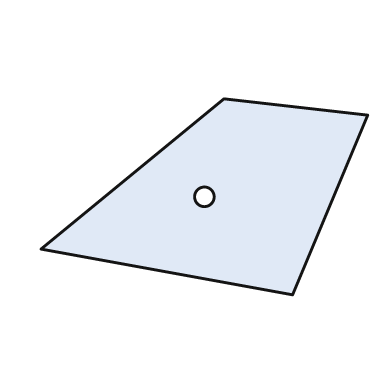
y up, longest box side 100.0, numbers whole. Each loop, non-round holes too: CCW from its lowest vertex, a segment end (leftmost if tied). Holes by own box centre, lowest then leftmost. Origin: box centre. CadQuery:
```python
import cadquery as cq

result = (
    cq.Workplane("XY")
    .moveTo(27.0, -30.0)
    .lineTo(50.0, 25.0)
    .lineTo(6.0, 30.0)
    .lineTo(-50.0, -16.0)
    .close()
    .moveTo(0.0, 0.0)
    .circle(3.0)
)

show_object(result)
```